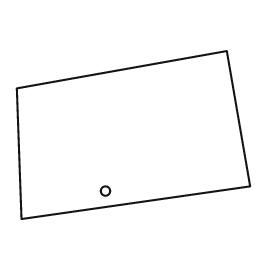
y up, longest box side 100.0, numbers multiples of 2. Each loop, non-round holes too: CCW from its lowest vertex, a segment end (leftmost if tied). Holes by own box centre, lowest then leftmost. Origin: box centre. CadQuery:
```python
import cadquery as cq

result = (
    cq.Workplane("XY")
    .moveTo(-48.0, -36.0)
    .lineTo(50.0, -22.0)
    .lineTo(40.0, 36.0)
    .lineTo(-50.0, 20.0)
    .close()
    .moveTo(-12.0, -24.0)
    .circle(2.0)
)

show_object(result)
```